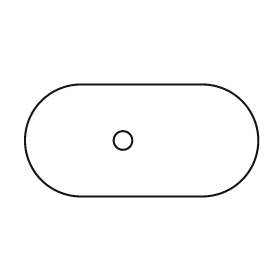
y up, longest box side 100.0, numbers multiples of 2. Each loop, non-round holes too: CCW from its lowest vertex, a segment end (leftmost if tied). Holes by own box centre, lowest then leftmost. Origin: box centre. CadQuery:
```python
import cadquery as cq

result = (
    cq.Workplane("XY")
    .moveTo(-26.0, -24.0)
    .lineTo(26.0, -24.0)
    .threePointArc((50.0, 0.0), (26.0, 24.0))
    .lineTo(-26.0, 24.0)
    .threePointArc((-50.0, 0.0), (-26.0, -24.0))
    .close()
    .moveTo(-8.0, 0.0)
    .circle(4.0)
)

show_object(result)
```